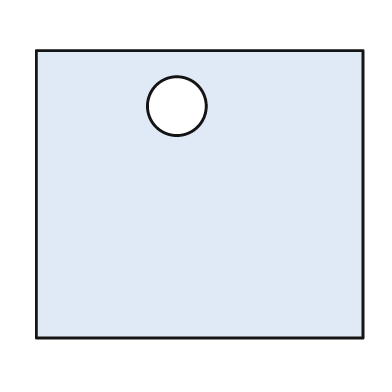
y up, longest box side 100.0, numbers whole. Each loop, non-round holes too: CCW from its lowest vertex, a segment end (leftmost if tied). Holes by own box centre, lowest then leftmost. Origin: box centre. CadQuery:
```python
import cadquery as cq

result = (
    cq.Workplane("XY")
    .moveTo(-50.0, -44.0)
    .lineTo(50.0, -44.0)
    .lineTo(50.0, 44.0)
    .lineTo(-50.0, 44.0)
    .close()
    .moveTo(-7.0, 27.0)
    .circle(9.0)
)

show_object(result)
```